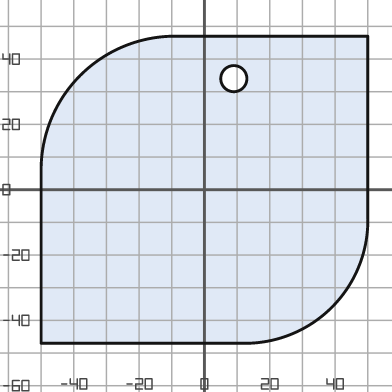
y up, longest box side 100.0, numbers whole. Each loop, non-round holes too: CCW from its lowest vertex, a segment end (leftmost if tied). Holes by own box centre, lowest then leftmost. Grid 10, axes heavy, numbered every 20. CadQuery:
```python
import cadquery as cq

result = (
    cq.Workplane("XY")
    .moveTo(-50.0, -47.0)
    .lineTo(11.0, -47.0)
    .threePointArc((39.0, -36.0), (50.0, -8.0))
    .lineTo(50.0, 47.0)
    .lineTo(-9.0, 47.0)
    .threePointArc((-38.0, 35.0), (-50.0, 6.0))
    .close()
    .moveTo(9.0, 34.0)
    .circle(4.0)
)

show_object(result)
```